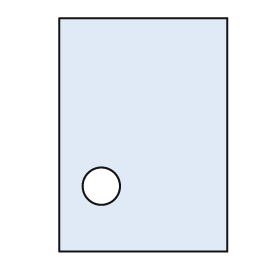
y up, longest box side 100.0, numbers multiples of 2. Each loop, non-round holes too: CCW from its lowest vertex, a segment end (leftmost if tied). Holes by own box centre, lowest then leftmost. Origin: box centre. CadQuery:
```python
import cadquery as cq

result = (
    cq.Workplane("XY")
    .moveTo(-36.0, -50.0)
    .lineTo(36.0, -50.0)
    .lineTo(36.0, 50.0)
    .lineTo(-36.0, 50.0)
    .close()
    .moveTo(-18.0, -22.0)
    .circle(8.0)
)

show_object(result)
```